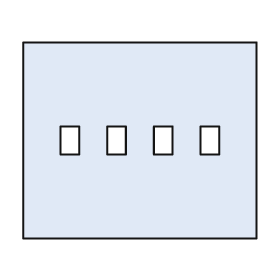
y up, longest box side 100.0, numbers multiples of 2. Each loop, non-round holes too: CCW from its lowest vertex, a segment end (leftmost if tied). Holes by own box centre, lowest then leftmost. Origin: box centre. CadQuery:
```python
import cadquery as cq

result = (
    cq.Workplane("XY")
    .moveTo(-50.0, -42.0)
    .lineTo(50.0, -42.0)
    .lineTo(50.0, 42.0)
    .lineTo(-50.0, 42.0)
    .close()
    .moveTo(-34.0, -6.0)
    .lineTo(-26.0, -6.0)
    .lineTo(-26.0, 6.0)
    .lineTo(-34.0, 6.0)
    .close()
    .moveTo(-14.0, -6.0)
    .lineTo(-6.0, -6.0)
    .lineTo(-6.0, 6.0)
    .lineTo(-14.0, 6.0)
    .close()
    .moveTo(6.0, -6.0)
    .lineTo(14.0, -6.0)
    .lineTo(14.0, 6.0)
    .lineTo(6.0, 6.0)
    .close()
    .moveTo(26.0, -6.0)
    .lineTo(34.0, -6.0)
    .lineTo(34.0, 6.0)
    .lineTo(26.0, 6.0)
    .close()
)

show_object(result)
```